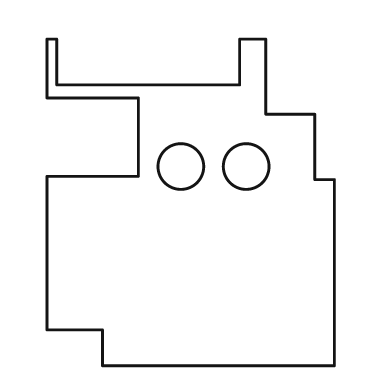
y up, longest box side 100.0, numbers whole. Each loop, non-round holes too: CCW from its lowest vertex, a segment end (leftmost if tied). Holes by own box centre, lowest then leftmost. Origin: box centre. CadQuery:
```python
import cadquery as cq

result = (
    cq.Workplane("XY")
    .moveTo(-27.0, -50.0)
    .lineTo(44.0, -50.0)
    .lineTo(44.0, 7.0)
    .lineTo(38.0, 7.0)
    .lineTo(38.0, 27.0)
    .lineTo(23.0, 27.0)
    .lineTo(23.0, 50.0)
    .lineTo(15.0, 50.0)
    .lineTo(15.0, 36.0)
    .lineTo(-41.0, 36.0)
    .lineTo(-41.0, 50.0)
    .lineTo(-44.0, 50.0)
    .lineTo(-44.0, 32.0)
    .lineTo(-16.0, 32.0)
    .lineTo(-16.0, 8.0)
    .lineTo(-44.0, 8.0)
    .lineTo(-44.0, -39.0)
    .lineTo(-27.0, -39.0)
    .close()
    .moveTo(-3.0, 11.0)
    .circle(7.0)
    .moveTo(17.0, 11.0)
    .circle(7.0)
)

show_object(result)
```